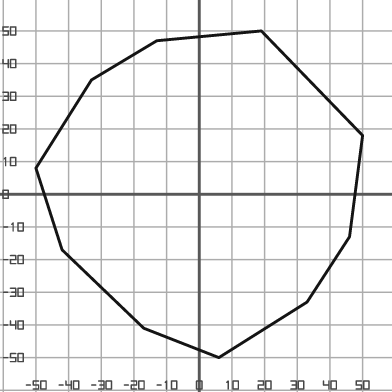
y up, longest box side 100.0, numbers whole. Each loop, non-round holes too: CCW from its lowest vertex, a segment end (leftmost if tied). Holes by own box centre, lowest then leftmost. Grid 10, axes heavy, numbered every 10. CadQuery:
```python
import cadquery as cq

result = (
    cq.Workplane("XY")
    .moveTo(6.0, -50.0)
    .lineTo(33.0, -33.0)
    .lineTo(46.0, -13.0)
    .lineTo(50.0, 18.0)
    .lineTo(19.0, 50.0)
    .lineTo(-13.0, 47.0)
    .lineTo(-33.0, 35.0)
    .lineTo(-50.0, 8.0)
    .lineTo(-42.0, -17.0)
    .lineTo(-17.0, -41.0)
    .close()
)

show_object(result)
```